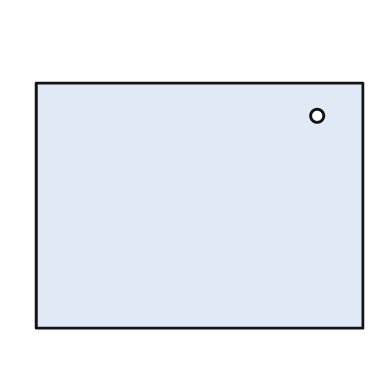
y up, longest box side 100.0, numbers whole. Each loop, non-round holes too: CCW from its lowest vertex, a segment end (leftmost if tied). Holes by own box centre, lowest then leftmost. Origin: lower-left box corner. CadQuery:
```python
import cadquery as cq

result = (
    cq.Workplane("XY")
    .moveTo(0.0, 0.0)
    .lineTo(100.0, 0.0)
    .lineTo(100.0, 75.0)
    .lineTo(0.0, 75.0)
    .close()
    .moveTo(86.0, 65.0)
    .circle(2.0)
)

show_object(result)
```